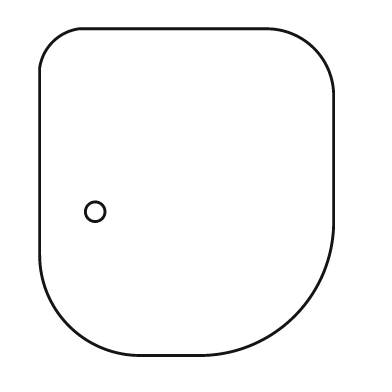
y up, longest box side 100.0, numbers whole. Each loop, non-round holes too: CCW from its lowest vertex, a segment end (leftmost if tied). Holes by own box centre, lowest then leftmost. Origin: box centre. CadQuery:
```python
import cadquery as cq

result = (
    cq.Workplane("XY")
    .moveTo(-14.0, -50.0)
    .lineTo(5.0, -50.0)
    .threePointArc((33.0, -38.0), (45.0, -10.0))
    .lineTo(45.0, 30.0)
    .threePointArc((39.0, 44.0), (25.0, 50.0))
    .lineTo(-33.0, 50.0)
    .threePointArc((-41.0, 46.0), (-45.0, 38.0))
    .lineTo(-45.0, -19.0)
    .threePointArc((-36.0, -41.0), (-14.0, -50.0))
    .close()
    .moveTo(-28.0, -6.0)
    .circle(3.0)
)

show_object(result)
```